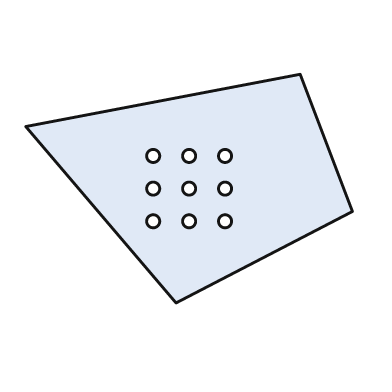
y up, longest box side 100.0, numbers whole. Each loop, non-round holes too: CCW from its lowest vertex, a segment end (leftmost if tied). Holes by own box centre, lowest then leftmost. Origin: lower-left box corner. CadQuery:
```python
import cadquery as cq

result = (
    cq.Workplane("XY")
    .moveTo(46.0, 0.0)
    .lineTo(100.0, 28.0)
    .lineTo(84.0, 70.0)
    .lineTo(0.0, 54.0)
    .close()
    .moveTo(39.0, 25.0)
    .circle(2.0)
    .moveTo(50.0, 25.0)
    .circle(2.0)
    .moveTo(61.0, 25.0)
    .circle(2.0)
    .moveTo(39.0, 35.0)
    .circle(2.0)
    .moveTo(50.0, 35.0)
    .circle(2.0)
    .moveTo(61.0, 35.0)
    .circle(2.0)
    .moveTo(39.0, 45.0)
    .circle(2.0)
    .moveTo(50.0, 45.0)
    .circle(2.0)
    .moveTo(61.0, 45.0)
    .circle(2.0)
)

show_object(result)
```